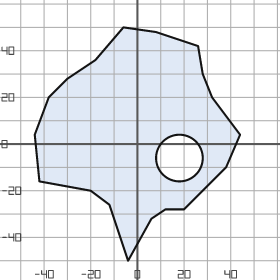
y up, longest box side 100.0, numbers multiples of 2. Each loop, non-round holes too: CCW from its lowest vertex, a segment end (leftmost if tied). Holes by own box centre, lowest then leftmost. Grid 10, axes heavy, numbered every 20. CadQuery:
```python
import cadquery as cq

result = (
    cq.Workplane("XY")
    .moveTo(-4.0, -50.0)
    .lineTo(6.0, -32.0)
    .lineTo(12.0, -28.0)
    .lineTo(20.0, -28.0)
    .lineTo(38.0, -10.0)
    .lineTo(44.0, 4.0)
    .lineTo(32.0, 20.0)
    .lineTo(28.0, 30.0)
    .lineTo(26.0, 42.0)
    .lineTo(8.0, 48.0)
    .lineTo(-6.0, 50.0)
    .lineTo(-18.0, 36.0)
    .lineTo(-30.0, 28.0)
    .lineTo(-38.0, 20.0)
    .lineTo(-44.0, 4.0)
    .lineTo(-42.0, -16.0)
    .lineTo(-20.0, -20.0)
    .lineTo(-12.0, -26.0)
    .close()
    .moveTo(18.0, -6.0)
    .circle(10.0)
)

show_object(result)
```